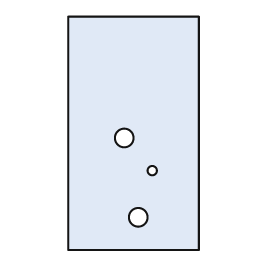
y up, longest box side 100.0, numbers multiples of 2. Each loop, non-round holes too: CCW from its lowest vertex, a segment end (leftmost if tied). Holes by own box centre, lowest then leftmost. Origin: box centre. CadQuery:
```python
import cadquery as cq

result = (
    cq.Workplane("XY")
    .moveTo(-28.0, -50.0)
    .lineTo(28.0, -50.0)
    .lineTo(28.0, 50.0)
    .lineTo(-28.0, 50.0)
    .close()
    .moveTo(2.0, -36.0)
    .circle(4.0)
    .moveTo(8.0, -16.0)
    .circle(2.0)
    .moveTo(-4.0, -2.0)
    .circle(4.0)
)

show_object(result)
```